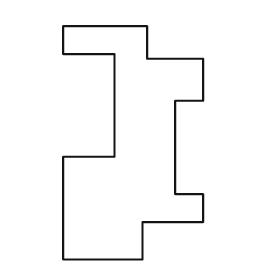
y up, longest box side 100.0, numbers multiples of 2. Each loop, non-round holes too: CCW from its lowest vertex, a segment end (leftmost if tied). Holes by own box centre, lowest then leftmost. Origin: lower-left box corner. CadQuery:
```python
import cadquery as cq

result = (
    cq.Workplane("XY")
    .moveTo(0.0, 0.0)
    .lineTo(34.0, 0.0)
    .lineTo(34.0, 16.0)
    .lineTo(60.0, 16.0)
    .lineTo(60.0, 28.0)
    .lineTo(48.0, 28.0)
    .lineTo(48.0, 68.0)
    .lineTo(60.0, 68.0)
    .lineTo(60.0, 86.0)
    .lineTo(36.0, 86.0)
    .lineTo(36.0, 100.0)
    .lineTo(0.0, 100.0)
    .lineTo(0.0, 88.0)
    .lineTo(22.0, 88.0)
    .lineTo(22.0, 44.0)
    .lineTo(0.0, 44.0)
    .close()
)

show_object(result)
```